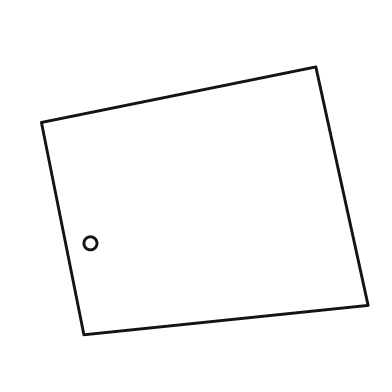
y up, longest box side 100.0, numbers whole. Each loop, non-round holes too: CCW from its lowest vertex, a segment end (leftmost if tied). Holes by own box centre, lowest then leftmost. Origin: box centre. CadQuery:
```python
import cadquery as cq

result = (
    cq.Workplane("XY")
    .moveTo(-37.0, -41.0)
    .lineTo(50.0, -32.0)
    .lineTo(34.0, 41.0)
    .lineTo(-50.0, 24.0)
    .close()
    .moveTo(-35.0, -13.0)
    .circle(2.0)
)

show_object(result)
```